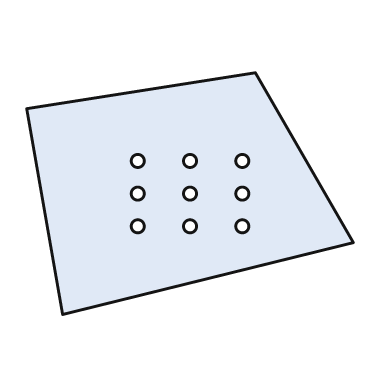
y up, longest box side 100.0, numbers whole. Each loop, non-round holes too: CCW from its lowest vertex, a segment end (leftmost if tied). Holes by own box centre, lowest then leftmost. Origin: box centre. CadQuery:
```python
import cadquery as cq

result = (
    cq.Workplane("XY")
    .moveTo(-39.0, -37.0)
    .lineTo(50.0, -15.0)
    .lineTo(20.0, 37.0)
    .lineTo(-50.0, 26.0)
    .close()
    .moveTo(-16.0, -10.0)
    .circle(2.0)
    .moveTo(0.0, -10.0)
    .circle(2.0)
    .moveTo(16.0, -10.0)
    .circle(2.0)
    .moveTo(-16.0, 0.0)
    .circle(2.0)
    .moveTo(0.0, 0.0)
    .circle(2.0)
    .moveTo(16.0, 0.0)
    .circle(2.0)
    .moveTo(-16.0, 10.0)
    .circle(2.0)
    .moveTo(0.0, 10.0)
    .circle(2.0)
    .moveTo(16.0, 10.0)
    .circle(2.0)
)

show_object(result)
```